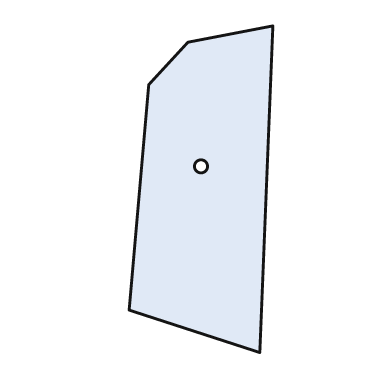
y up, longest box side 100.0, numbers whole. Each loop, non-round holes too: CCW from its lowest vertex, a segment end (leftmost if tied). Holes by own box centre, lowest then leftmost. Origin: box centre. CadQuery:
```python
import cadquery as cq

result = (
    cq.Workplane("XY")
    .moveTo(18.0, -50.0)
    .lineTo(22.0, 50.0)
    .lineTo(-4.0, 45.0)
    .lineTo(-16.0, 32.0)
    .lineTo(-22.0, -37.0)
    .close()
    .moveTo(0.0, 7.0)
    .circle(2.0)
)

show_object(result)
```